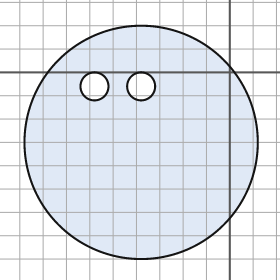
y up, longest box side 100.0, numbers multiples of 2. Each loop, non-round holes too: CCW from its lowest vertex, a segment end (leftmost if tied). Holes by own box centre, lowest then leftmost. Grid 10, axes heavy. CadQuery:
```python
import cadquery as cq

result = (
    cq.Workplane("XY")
    .moveTo(-38.0, -30.0)
    .circle(50.0)
    .moveTo(-58.0, -6.0)
    .circle(6.0)
    .moveTo(-38.0, -6.0)
    .circle(6.0)
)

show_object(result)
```